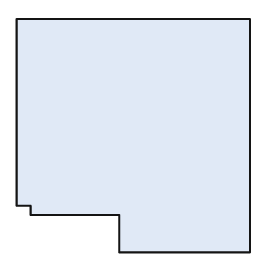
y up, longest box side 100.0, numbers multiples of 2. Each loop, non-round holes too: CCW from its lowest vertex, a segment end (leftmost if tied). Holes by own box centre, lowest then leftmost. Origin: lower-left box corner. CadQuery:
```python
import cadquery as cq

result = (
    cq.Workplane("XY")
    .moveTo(44.0, 0.0)
    .lineTo(100.0, 0.0)
    .lineTo(100.0, 100.0)
    .lineTo(0.0, 100.0)
    .lineTo(0.0, 20.0)
    .lineTo(6.0, 20.0)
    .lineTo(6.0, 16.0)
    .lineTo(44.0, 16.0)
    .close()
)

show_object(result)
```